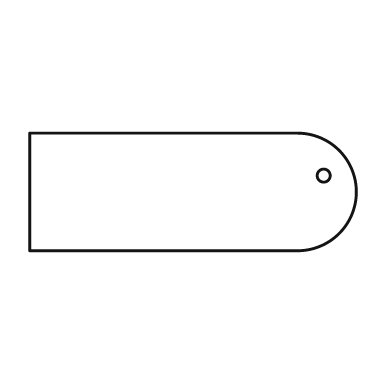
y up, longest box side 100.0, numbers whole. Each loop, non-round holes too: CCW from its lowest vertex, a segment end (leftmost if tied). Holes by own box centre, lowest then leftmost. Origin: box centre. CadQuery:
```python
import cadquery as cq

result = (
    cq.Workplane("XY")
    .moveTo(-50.0, -18.0)
    .lineTo(32.0, -18.0)
    .threePointArc((50.0, 0.0), (32.0, 18.0))
    .lineTo(-50.0, 18.0)
    .close()
    .moveTo(40.0, 5.0)
    .circle(2.0)
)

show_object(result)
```